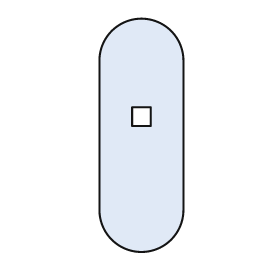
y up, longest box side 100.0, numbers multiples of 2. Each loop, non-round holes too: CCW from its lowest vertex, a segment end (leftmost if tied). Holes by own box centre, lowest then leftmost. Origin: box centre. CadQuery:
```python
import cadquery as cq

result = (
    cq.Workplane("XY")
    .moveTo(-18.0, -32.0)
    .threePointArc((0.0, -50.0), (18.0, -32.0))
    .lineTo(18.0, 32.0)
    .threePointArc((0.0, 50.0), (-18.0, 32.0))
    .close()
    .moveTo(-4.0, 4.0)
    .lineTo(4.0, 4.0)
    .lineTo(4.0, 12.0)
    .lineTo(-4.0, 12.0)
    .close()
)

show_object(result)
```